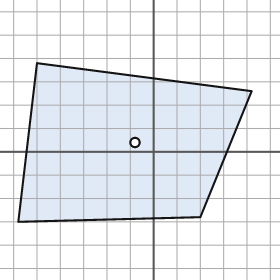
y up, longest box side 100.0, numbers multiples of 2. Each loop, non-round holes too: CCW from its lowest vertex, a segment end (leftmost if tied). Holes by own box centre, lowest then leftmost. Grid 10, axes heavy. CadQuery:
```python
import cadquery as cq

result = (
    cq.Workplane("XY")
    .moveTo(-58.0, -30.0)
    .lineTo(20.0, -28.0)
    .lineTo(42.0, 26.0)
    .lineTo(-50.0, 38.0)
    .close()
    .moveTo(-8.0, 4.0)
    .circle(2.0)
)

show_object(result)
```